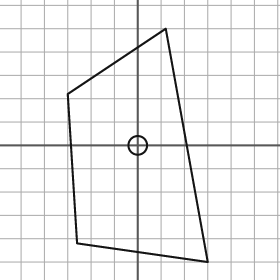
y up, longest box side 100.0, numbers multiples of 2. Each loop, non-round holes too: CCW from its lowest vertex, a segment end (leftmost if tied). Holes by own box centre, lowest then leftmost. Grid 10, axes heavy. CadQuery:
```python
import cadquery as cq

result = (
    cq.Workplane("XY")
    .moveTo(30.0, -50.0)
    .lineTo(12.0, 50.0)
    .lineTo(-30.0, 22.0)
    .lineTo(-26.0, -42.0)
    .close()
    .moveTo(0.0, 0.0)
    .circle(4.0)
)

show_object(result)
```